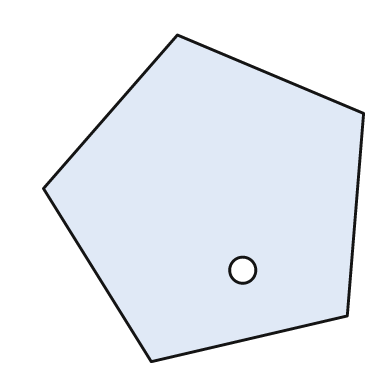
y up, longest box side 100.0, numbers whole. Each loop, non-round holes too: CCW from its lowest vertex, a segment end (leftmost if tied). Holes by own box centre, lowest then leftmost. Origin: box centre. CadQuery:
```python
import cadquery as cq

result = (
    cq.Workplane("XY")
    .moveTo(-16.0, -50.0)
    .lineTo(44.0, -36.0)
    .lineTo(49.0, 26.0)
    .lineTo(-8.0, 50.0)
    .lineTo(-49.0, 3.0)
    .close()
    .moveTo(12.0, -22.0)
    .circle(4.0)
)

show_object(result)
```